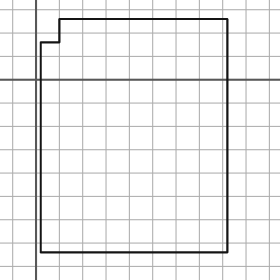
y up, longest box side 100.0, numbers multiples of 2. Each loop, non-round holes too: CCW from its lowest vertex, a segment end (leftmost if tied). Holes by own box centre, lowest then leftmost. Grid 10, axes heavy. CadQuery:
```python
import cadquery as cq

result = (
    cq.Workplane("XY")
    .moveTo(2.0, -74.0)
    .lineTo(82.0, -74.0)
    .lineTo(82.0, 26.0)
    .lineTo(10.0, 26.0)
    .lineTo(10.0, 16.0)
    .lineTo(2.0, 16.0)
    .close()
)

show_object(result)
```